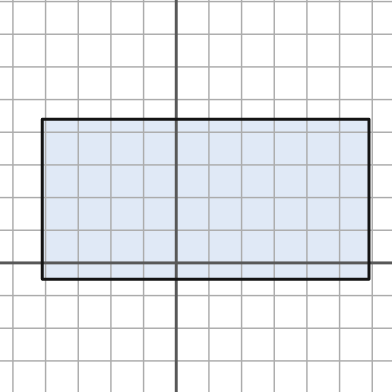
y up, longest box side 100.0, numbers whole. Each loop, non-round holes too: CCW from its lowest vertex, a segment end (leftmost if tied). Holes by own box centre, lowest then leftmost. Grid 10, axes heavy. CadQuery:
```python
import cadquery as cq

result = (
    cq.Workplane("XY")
    .moveTo(-41.0, -5.0)
    .lineTo(59.0, -5.0)
    .lineTo(59.0, 44.0)
    .lineTo(-41.0, 44.0)
    .close()
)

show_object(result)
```